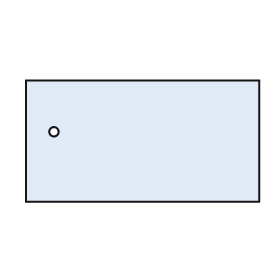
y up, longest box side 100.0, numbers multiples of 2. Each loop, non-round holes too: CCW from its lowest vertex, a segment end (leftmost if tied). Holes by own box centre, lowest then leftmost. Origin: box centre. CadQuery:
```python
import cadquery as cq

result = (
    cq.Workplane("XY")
    .moveTo(-50.0, -26.0)
    .lineTo(50.0, -26.0)
    .lineTo(50.0, 26.0)
    .lineTo(-50.0, 26.0)
    .close()
    .moveTo(-38.0, 4.0)
    .circle(2.0)
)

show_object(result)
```